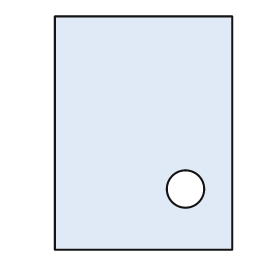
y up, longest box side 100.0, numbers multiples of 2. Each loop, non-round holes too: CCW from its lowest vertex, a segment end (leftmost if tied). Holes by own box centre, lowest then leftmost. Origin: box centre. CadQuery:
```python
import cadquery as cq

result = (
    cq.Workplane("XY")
    .moveTo(-38.0, -50.0)
    .lineTo(38.0, -50.0)
    .lineTo(38.0, 50.0)
    .lineTo(-38.0, 50.0)
    .close()
    .moveTo(18.0, -24.0)
    .circle(8.0)
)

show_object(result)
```